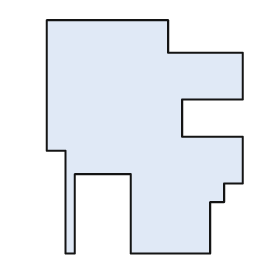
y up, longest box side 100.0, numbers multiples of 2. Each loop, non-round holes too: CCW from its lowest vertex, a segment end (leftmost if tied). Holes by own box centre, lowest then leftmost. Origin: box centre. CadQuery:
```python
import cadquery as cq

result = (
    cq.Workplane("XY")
    .moveTo(-34.0, -50.0)
    .lineTo(-30.0, -50.0)
    .lineTo(-30.0, -16.0)
    .lineTo(-6.0, -16.0)
    .lineTo(-6.0, -50.0)
    .lineTo(28.0, -50.0)
    .lineTo(28.0, -28.0)
    .lineTo(34.0, -28.0)
    .lineTo(34.0, -20.0)
    .lineTo(42.0, -20.0)
    .lineTo(42.0, 0.0)
    .lineTo(16.0, 0.0)
    .lineTo(16.0, 16.0)
    .lineTo(42.0, 16.0)
    .lineTo(42.0, 36.0)
    .lineTo(10.0, 36.0)
    .lineTo(10.0, 50.0)
    .lineTo(-42.0, 50.0)
    .lineTo(-42.0, -6.0)
    .lineTo(-34.0, -6.0)
    .close()
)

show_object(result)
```